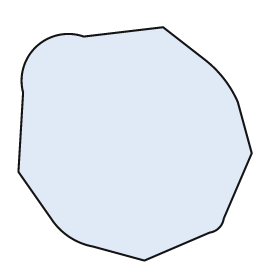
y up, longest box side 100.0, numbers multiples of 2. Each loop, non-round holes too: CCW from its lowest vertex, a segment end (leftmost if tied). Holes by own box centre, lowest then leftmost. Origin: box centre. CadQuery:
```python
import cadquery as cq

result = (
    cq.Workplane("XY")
    .moveTo(4.0, -50.0)
    .lineTo(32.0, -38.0)
    .threePointArc((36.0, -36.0), (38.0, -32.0))
    .lineTo(50.0, -4.0)
    .lineTo(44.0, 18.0)
    .threePointArc((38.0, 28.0), (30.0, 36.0))
    .lineTo(12.0, 50.0)
    .lineTo(-22.0, 46.0)
    .threePointArc((-42.0, 42.0), (-48.0, 22.0))
    .lineTo(-50.0, -12.0)
    .lineTo(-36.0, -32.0)
    .threePointArc((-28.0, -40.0), (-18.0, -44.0))
    .close()
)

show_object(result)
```